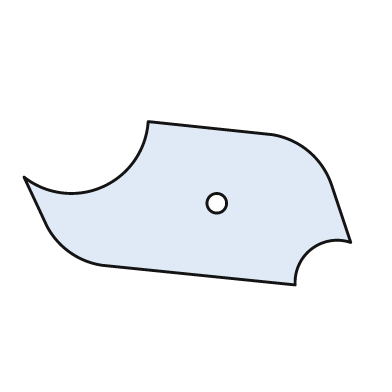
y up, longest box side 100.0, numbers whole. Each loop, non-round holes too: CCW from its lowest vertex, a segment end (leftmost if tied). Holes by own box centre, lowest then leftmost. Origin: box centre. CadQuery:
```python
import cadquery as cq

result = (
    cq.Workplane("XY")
    .moveTo(33.0, -25.0)
    .threePointArc((38.0, -14.0), (50.0, -12.0))
    .lineTo(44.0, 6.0)
    .threePointArc((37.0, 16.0), (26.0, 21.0))
    .lineTo(-12.0, 25.0)
    .threePointArc((-26.0, 5.0), (-50.0, 8.0))
    .lineTo(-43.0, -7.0)
    .threePointArc((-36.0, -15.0), (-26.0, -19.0))
    .close()
    .moveTo(9.0, 0.0)
    .circle(3.0)
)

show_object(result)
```